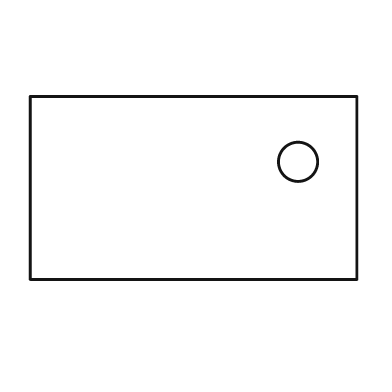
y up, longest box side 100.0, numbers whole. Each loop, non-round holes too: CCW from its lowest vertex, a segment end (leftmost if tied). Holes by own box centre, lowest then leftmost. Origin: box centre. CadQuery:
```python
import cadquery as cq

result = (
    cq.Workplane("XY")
    .moveTo(-50.0, -28.0)
    .lineTo(50.0, -28.0)
    .lineTo(50.0, 28.0)
    .lineTo(-50.0, 28.0)
    .close()
    .moveTo(32.0, 8.0)
    .circle(6.0)
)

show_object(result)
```